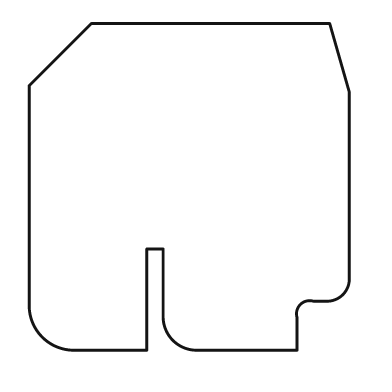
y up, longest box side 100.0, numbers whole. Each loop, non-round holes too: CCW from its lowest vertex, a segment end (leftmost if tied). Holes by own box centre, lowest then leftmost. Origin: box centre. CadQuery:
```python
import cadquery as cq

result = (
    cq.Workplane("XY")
    .moveTo(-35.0, -50.0)
    .lineTo(-13.0, -50.0)
    .lineTo(-13.0, -19.0)
    .lineTo(-8.0, -19.0)
    .lineTo(-8.0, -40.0)
    .threePointArc((-5.0, -47.0), (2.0, -50.0))
    .lineTo(33.0, -50.0)
    .lineTo(33.0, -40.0)
    .threePointArc((34.0, -36.0), (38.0, -35.0))
    .lineTo(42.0, -35.0)
    .threePointArc((47.0, -33.0), (49.0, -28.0))
    .lineTo(49.0, 29.0)
    .lineTo(43.0, 50.0)
    .lineTo(-30.0, 50.0)
    .lineTo(-49.0, 31.0)
    .lineTo(-49.0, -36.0)
    .threePointArc((-45.0, -46.0), (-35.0, -50.0))
    .close()
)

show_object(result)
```